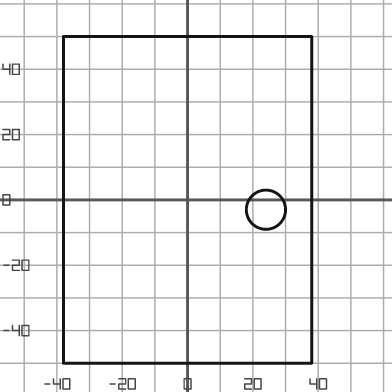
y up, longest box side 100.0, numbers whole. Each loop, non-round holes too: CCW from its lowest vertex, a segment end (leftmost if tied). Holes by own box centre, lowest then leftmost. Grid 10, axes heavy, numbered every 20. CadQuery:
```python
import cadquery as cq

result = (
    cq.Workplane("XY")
    .moveTo(-38.0, -50.0)
    .lineTo(38.0, -50.0)
    .lineTo(38.0, 50.0)
    .lineTo(-38.0, 50.0)
    .close()
    .moveTo(24.0, -3.0)
    .circle(6.0)
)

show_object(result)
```